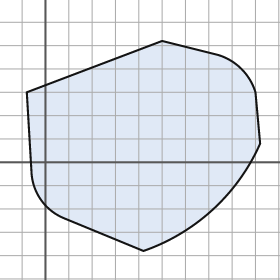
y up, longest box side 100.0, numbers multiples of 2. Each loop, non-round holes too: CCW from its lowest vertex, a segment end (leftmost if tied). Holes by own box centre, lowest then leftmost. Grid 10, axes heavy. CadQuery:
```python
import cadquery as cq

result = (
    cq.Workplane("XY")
    .moveTo(42.0, -38.0)
    .threePointArc((72.0, -20.0), (92.0, 8.0))
    .lineTo(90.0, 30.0)
    .threePointArc((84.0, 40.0), (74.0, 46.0))
    .lineTo(50.0, 52.0)
    .lineTo(-8.0, 30.0)
    .lineTo(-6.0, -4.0)
    .threePointArc((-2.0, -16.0), (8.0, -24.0))
    .close()
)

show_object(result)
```